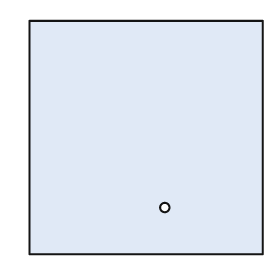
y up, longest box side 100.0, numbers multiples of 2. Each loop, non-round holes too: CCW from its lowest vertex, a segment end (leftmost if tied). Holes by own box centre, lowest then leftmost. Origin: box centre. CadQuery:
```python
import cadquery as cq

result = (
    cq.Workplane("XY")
    .moveTo(-50.0, -50.0)
    .lineTo(50.0, -50.0)
    .lineTo(50.0, 50.0)
    .lineTo(-50.0, 50.0)
    .close()
    .moveTo(8.0, -30.0)
    .circle(2.0)
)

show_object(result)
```